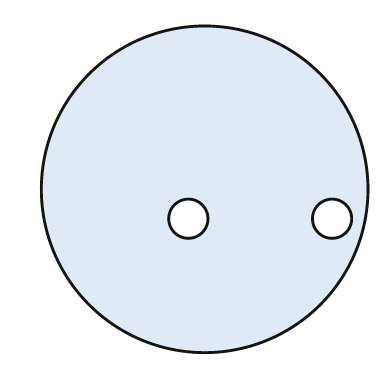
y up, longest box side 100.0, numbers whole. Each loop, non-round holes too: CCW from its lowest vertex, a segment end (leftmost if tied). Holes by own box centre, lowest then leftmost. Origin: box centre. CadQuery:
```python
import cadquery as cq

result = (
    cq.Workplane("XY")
    .moveTo(0.0, 0.0)
    .circle(50.0)
    .moveTo(-5.0, -9.0)
    .circle(6.0)
    .moveTo(39.0, -9.0)
    .circle(6.0)
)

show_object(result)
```